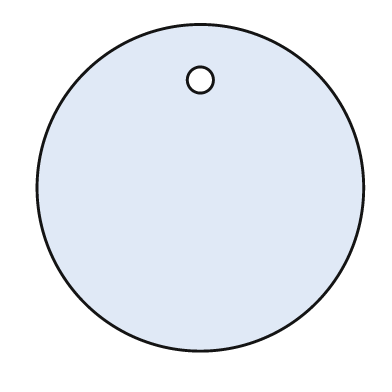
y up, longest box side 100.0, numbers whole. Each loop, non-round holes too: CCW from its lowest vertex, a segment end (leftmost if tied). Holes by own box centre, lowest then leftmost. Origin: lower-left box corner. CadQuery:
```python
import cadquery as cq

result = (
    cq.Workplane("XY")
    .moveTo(50.0, 50.0)
    .circle(50.0)
    .moveTo(50.0, 83.0)
    .circle(4.0)
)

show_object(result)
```